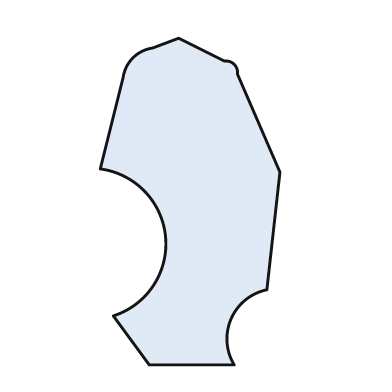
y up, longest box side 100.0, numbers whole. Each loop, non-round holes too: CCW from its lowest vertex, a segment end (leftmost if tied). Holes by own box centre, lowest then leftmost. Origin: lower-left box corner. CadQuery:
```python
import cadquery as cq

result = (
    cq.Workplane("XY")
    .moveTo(15.0, 0.0)
    .lineTo(41.0, 0.0)
    .threePointArc((40.0, 14.0), (51.0, 23.0))
    .lineTo(55.0, 59.0)
    .lineTo(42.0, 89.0)
    .threePointArc((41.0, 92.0), (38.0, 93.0))
    .lineTo(24.0, 100.0)
    .lineTo(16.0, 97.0)
    .threePointArc((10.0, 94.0), (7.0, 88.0))
    .lineTo(0.0, 60.0)
    .threePointArc((20.0, 39.0), (4.0, 15.0))
    .close()
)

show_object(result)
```